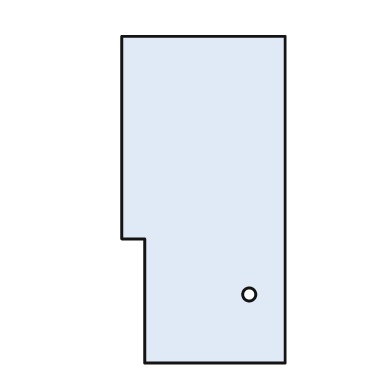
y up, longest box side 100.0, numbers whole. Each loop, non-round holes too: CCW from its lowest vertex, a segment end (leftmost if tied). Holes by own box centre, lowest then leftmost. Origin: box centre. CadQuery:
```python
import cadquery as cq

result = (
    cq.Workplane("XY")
    .moveTo(-18.0, -50.0)
    .lineTo(25.0, -50.0)
    .lineTo(25.0, 50.0)
    .lineTo(-25.0, 50.0)
    .lineTo(-25.0, -12.0)
    .lineTo(-18.0, -12.0)
    .close()
    .moveTo(14.0, -29.0)
    .circle(2.0)
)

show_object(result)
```